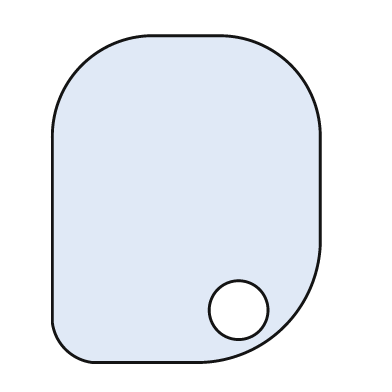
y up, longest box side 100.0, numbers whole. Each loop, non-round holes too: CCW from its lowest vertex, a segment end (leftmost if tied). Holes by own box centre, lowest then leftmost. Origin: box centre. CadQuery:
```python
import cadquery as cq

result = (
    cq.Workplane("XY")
    .moveTo(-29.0, -50.0)
    .lineTo(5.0, -50.0)
    .threePointArc((30.0, -39.0), (41.0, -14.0))
    .lineTo(41.0, 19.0)
    .threePointArc((32.0, 41.0), (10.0, 50.0))
    .lineTo(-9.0, 50.0)
    .threePointArc((-32.0, 41.0), (-41.0, 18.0))
    .lineTo(-41.0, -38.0)
    .threePointArc((-37.0, -46.0), (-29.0, -50.0))
    .close()
    .moveTo(16.0, -34.0)
    .circle(9.0)
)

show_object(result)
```